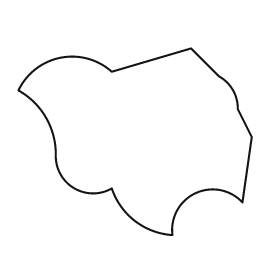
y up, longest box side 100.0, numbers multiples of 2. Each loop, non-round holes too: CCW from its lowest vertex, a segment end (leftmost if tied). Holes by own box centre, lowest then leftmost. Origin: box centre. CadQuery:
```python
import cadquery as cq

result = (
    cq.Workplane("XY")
    .moveTo(16.0, -40.0)
    .threePointArc((26.0, -22.0), (46.0, -26.0))
    .lineTo(50.0, 2.0)
    .lineTo(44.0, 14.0)
    .threePointArc((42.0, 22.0), (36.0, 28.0))
    .lineTo(24.0, 40.0)
    .lineTo(-10.0, 30.0)
    .threePointArc((-32.0, 36.0), (-50.0, 22.0))
    .threePointArc((-38.0, 10.0), (-34.0, -6.0))
    .threePointArc((-26.0, -20.0), (-10.0, -20.0))
    .threePointArc((0.0, -34.0), (16.0, -40.0))
    .close()
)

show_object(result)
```